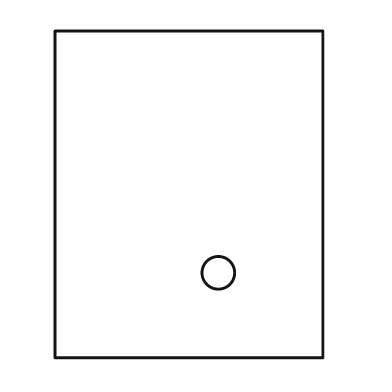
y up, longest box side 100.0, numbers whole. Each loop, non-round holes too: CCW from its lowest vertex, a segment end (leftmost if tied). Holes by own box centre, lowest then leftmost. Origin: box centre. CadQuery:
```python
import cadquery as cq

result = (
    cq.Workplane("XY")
    .moveTo(-41.0, -50.0)
    .lineTo(41.0, -50.0)
    .lineTo(41.0, 50.0)
    .lineTo(-41.0, 50.0)
    .close()
    .moveTo(9.0, -24.0)
    .circle(5.0)
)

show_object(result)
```